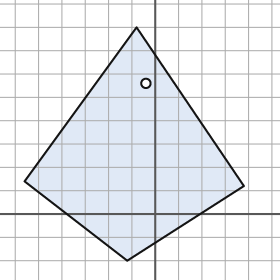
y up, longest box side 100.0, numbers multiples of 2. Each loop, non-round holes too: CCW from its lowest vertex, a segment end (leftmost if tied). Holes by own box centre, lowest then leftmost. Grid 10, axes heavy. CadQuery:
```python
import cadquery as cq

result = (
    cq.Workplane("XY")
    .moveTo(-12.0, -20.0)
    .lineTo(38.0, 12.0)
    .lineTo(-8.0, 80.0)
    .lineTo(-56.0, 14.0)
    .close()
    .moveTo(-4.0, 56.0)
    .circle(2.0)
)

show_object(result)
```